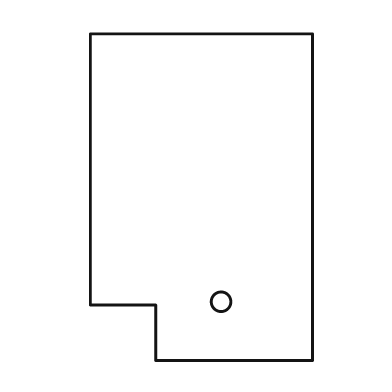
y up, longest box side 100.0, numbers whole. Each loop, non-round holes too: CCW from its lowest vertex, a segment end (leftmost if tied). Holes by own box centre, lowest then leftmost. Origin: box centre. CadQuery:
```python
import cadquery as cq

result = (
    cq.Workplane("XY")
    .moveTo(-14.0, -50.0)
    .lineTo(34.0, -50.0)
    .lineTo(34.0, 50.0)
    .lineTo(-34.0, 50.0)
    .lineTo(-34.0, -33.0)
    .lineTo(-14.0, -33.0)
    .close()
    .moveTo(6.0, -32.0)
    .circle(3.0)
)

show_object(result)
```